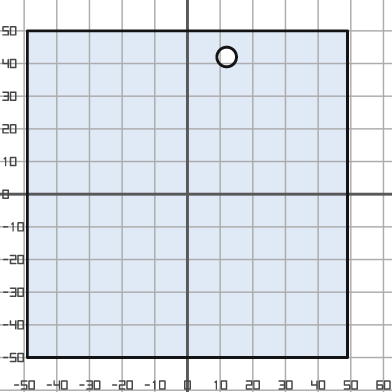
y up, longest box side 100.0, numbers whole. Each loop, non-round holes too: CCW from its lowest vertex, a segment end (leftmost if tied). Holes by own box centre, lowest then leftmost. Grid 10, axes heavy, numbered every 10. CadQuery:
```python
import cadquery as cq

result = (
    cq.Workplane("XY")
    .moveTo(-49.0, -50.0)
    .lineTo(49.0, -50.0)
    .lineTo(49.0, 50.0)
    .lineTo(-49.0, 50.0)
    .close()
    .moveTo(12.0, 42.0)
    .circle(3.0)
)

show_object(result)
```